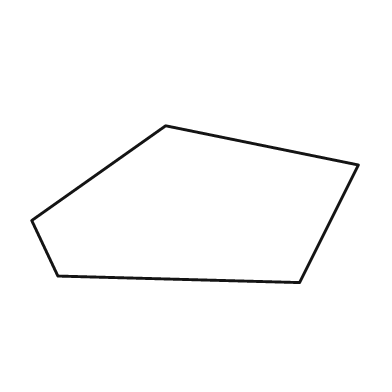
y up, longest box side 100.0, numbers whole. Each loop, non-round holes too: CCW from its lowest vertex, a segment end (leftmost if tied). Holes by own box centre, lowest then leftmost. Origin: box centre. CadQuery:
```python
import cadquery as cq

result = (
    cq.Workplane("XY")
    .moveTo(32.0, -24.0)
    .lineTo(50.0, 12.0)
    .lineTo(-9.0, 24.0)
    .lineTo(-50.0, -5.0)
    .lineTo(-42.0, -22.0)
    .close()
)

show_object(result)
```